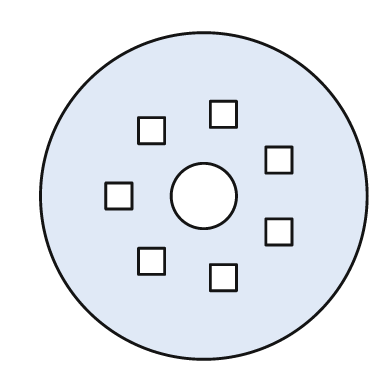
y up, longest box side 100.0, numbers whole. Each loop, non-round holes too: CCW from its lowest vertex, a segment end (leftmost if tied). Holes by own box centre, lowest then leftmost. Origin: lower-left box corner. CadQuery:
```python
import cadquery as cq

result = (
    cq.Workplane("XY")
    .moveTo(50.0, 50.0)
    .circle(50.0)
    .moveTo(52.0, 21.0)
    .lineTo(60.0, 21.0)
    .lineTo(60.0, 29.0)
    .lineTo(52.0, 29.0)
    .close()
    .moveTo(30.0, 26.0)
    .lineTo(38.0, 26.0)
    .lineTo(38.0, 34.0)
    .lineTo(30.0, 34.0)
    .close()
    .moveTo(69.0, 35.0)
    .lineTo(77.0, 35.0)
    .lineTo(77.0, 43.0)
    .lineTo(69.0, 43.0)
    .close()
    .moveTo(20.0, 46.0)
    .lineTo(28.0, 46.0)
    .lineTo(28.0, 54.0)
    .lineTo(20.0, 54.0)
    .close()
    .moveTo(50.0, 50.0)
    .circle(10.0)
    .moveTo(69.0, 57.0)
    .lineTo(77.0, 57.0)
    .lineTo(77.0, 65.0)
    .lineTo(69.0, 65.0)
    .close()
    .moveTo(30.0, 66.0)
    .lineTo(38.0, 66.0)
    .lineTo(38.0, 74.0)
    .lineTo(30.0, 74.0)
    .close()
    .moveTo(52.0, 71.0)
    .lineTo(60.0, 71.0)
    .lineTo(60.0, 79.0)
    .lineTo(52.0, 79.0)
    .close()
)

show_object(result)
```